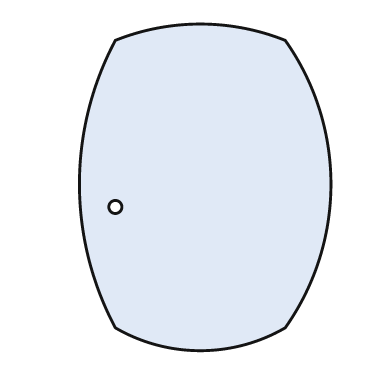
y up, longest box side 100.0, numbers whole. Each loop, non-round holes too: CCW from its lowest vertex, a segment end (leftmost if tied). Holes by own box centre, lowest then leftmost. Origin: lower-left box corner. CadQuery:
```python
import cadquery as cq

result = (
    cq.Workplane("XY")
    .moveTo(11.0, 7.0)
    .threePointArc((37.0, 0.0), (63.0, 7.0))
    .threePointArc((77.0, 51.0), (63.0, 95.0))
    .threePointArc((37.0, 100.0), (11.0, 95.0))
    .threePointArc((0.0, 51.0), (11.0, 7.0))
    .close()
    .moveTo(11.0, 44.0)
    .circle(2.0)
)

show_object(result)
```